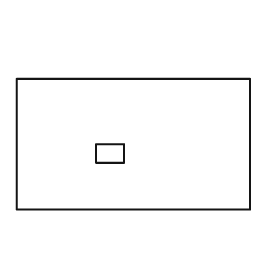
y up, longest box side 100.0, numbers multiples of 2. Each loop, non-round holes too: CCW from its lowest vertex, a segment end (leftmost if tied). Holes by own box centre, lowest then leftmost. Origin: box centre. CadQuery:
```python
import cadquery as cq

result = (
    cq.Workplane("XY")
    .moveTo(-50.0, -28.0)
    .lineTo(50.0, -28.0)
    .lineTo(50.0, 28.0)
    .lineTo(-50.0, 28.0)
    .close()
    .moveTo(-16.0, -8.0)
    .lineTo(-4.0, -8.0)
    .lineTo(-4.0, 0.0)
    .lineTo(-16.0, 0.0)
    .close()
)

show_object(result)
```